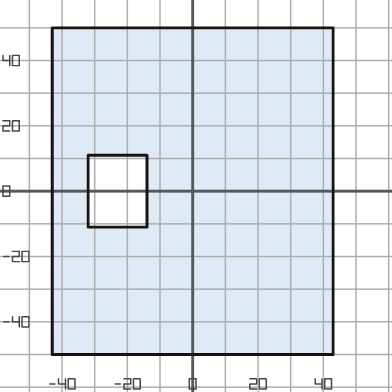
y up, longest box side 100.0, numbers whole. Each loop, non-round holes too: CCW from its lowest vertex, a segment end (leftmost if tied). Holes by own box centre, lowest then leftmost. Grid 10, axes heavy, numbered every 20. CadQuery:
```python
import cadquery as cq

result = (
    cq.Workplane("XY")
    .moveTo(-43.0, -50.0)
    .lineTo(43.0, -50.0)
    .lineTo(43.0, 50.0)
    .lineTo(-43.0, 50.0)
    .close()
    .moveTo(-32.0, -11.0)
    .lineTo(-14.0, -11.0)
    .lineTo(-14.0, 11.0)
    .lineTo(-32.0, 11.0)
    .close()
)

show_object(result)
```